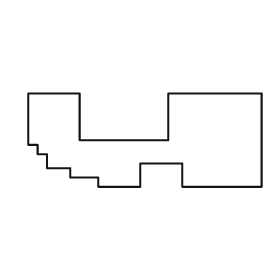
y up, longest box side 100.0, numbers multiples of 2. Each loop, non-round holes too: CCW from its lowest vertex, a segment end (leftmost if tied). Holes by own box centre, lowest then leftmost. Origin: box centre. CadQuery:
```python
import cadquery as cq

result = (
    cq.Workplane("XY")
    .moveTo(-20.0, -20.0)
    .lineTo(-2.0, -20.0)
    .lineTo(-2.0, -10.0)
    .lineTo(16.0, -10.0)
    .lineTo(16.0, -20.0)
    .lineTo(50.0, -20.0)
    .lineTo(50.0, 20.0)
    .lineTo(10.0, 20.0)
    .lineTo(10.0, 0.0)
    .lineTo(-28.0, 0.0)
    .lineTo(-28.0, 20.0)
    .lineTo(-50.0, 20.0)
    .lineTo(-50.0, -2.0)
    .lineTo(-46.0, -2.0)
    .lineTo(-46.0, -6.0)
    .lineTo(-42.0, -6.0)
    .lineTo(-42.0, -12.0)
    .lineTo(-32.0, -12.0)
    .lineTo(-32.0, -16.0)
    .lineTo(-20.0, -16.0)
    .close()
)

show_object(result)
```